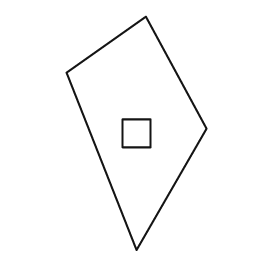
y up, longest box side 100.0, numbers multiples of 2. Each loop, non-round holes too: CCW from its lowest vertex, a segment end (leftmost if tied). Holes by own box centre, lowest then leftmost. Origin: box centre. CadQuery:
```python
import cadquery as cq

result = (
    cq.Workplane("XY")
    .moveTo(0.0, -50.0)
    .lineTo(30.0, 2.0)
    .lineTo(4.0, 50.0)
    .lineTo(-30.0, 26.0)
    .close()
    .moveTo(-6.0, -6.0)
    .lineTo(6.0, -6.0)
    .lineTo(6.0, 6.0)
    .lineTo(-6.0, 6.0)
    .close()
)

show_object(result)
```